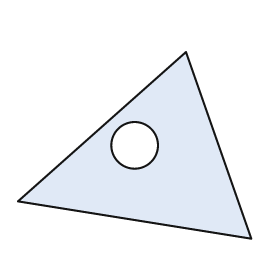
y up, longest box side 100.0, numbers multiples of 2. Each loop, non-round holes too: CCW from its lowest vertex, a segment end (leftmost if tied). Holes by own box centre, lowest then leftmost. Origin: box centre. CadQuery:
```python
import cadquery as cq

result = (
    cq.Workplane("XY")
    .moveTo(50.0, -40.0)
    .lineTo(22.0, 40.0)
    .lineTo(-50.0, -24.0)
    .close()
    .moveTo(0.0, 0.0)
    .circle(10.0)
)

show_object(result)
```